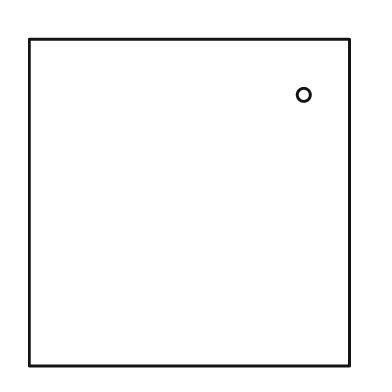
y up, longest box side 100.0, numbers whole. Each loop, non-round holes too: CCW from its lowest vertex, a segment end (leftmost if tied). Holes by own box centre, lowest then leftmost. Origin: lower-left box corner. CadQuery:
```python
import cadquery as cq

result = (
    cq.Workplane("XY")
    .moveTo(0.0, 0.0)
    .lineTo(98.0, 0.0)
    .lineTo(98.0, 100.0)
    .lineTo(0.0, 100.0)
    .close()
    .moveTo(84.0, 83.0)
    .circle(2.0)
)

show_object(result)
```